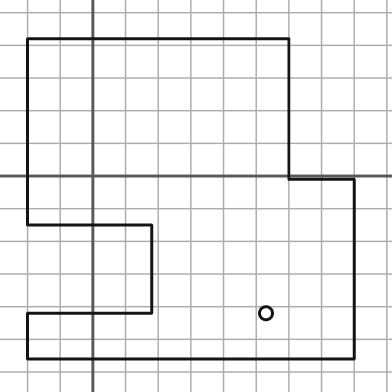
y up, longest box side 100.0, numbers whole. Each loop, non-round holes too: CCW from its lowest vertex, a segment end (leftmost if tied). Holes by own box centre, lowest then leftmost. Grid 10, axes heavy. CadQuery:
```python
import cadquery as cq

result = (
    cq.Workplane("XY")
    .moveTo(-20.0, -56.0)
    .lineTo(80.0, -56.0)
    .lineTo(80.0, -1.0)
    .lineTo(60.0, -1.0)
    .lineTo(60.0, 42.0)
    .lineTo(-20.0, 42.0)
    .lineTo(-20.0, -15.0)
    .lineTo(18.0, -15.0)
    .lineTo(18.0, -42.0)
    .lineTo(-20.0, -42.0)
    .close()
    .moveTo(53.0, -42.0)
    .circle(2.0)
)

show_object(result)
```